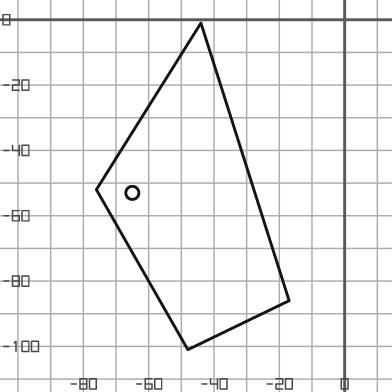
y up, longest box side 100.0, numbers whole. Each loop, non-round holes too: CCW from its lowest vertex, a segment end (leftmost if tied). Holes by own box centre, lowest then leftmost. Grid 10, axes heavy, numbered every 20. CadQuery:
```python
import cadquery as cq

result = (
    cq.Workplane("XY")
    .moveTo(-48.0, -101.0)
    .lineTo(-17.0, -86.0)
    .lineTo(-44.0, -1.0)
    .lineTo(-76.0, -52.0)
    .close()
    .moveTo(-65.0, -53.0)
    .circle(2.0)
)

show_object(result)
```